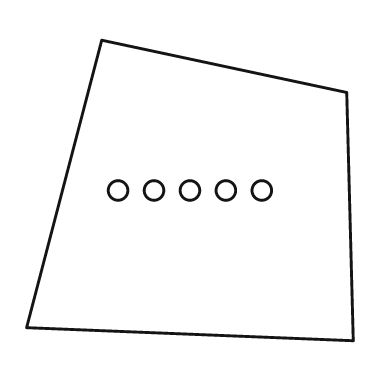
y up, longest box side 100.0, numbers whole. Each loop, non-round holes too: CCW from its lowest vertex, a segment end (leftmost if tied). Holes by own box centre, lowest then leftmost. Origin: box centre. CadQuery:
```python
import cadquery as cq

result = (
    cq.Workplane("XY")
    .moveTo(50.0, -46.0)
    .lineTo(48.0, 30.0)
    .lineTo(-27.0, 46.0)
    .lineTo(-50.0, -42.0)
    .close()
    .moveTo(-22.0, 0.0)
    .circle(3.0)
    .moveTo(-11.0, 0.0)
    .circle(3.0)
    .moveTo(0.0, 0.0)
    .circle(3.0)
    .moveTo(11.0, 0.0)
    .circle(3.0)
    .moveTo(22.0, 0.0)
    .circle(3.0)
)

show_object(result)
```